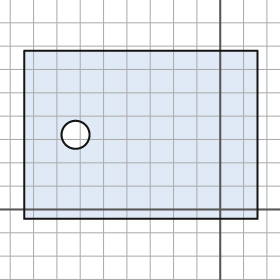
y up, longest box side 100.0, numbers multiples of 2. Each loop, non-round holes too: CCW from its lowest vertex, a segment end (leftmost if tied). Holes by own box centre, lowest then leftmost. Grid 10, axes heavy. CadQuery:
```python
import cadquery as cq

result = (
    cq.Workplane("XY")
    .moveTo(-84.0, -4.0)
    .lineTo(16.0, -4.0)
    .lineTo(16.0, 68.0)
    .lineTo(-84.0, 68.0)
    .close()
    .moveTo(-62.0, 32.0)
    .circle(6.0)
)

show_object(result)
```